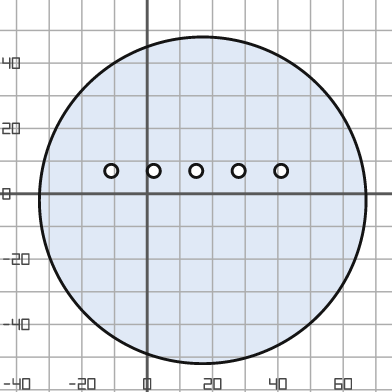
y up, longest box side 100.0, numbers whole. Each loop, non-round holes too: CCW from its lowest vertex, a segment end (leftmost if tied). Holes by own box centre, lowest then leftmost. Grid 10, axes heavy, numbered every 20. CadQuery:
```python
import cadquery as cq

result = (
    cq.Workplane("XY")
    .moveTo(17.0, -2.0)
    .circle(50.0)
    .moveTo(-11.0, 7.0)
    .circle(2.0)
    .moveTo(2.0, 7.0)
    .circle(2.0)
    .moveTo(15.0, 7.0)
    .circle(2.0)
    .moveTo(28.0, 7.0)
    .circle(2.0)
    .moveTo(41.0, 7.0)
    .circle(2.0)
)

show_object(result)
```